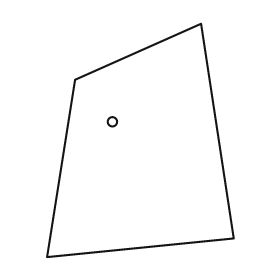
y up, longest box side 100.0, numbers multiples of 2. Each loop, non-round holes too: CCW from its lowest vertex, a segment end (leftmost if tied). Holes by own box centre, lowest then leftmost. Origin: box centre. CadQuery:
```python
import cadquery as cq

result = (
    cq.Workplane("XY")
    .moveTo(-40.0, -50.0)
    .lineTo(40.0, -42.0)
    .lineTo(26.0, 50.0)
    .lineTo(-28.0, 26.0)
    .close()
    .moveTo(-12.0, 8.0)
    .circle(2.0)
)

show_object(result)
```